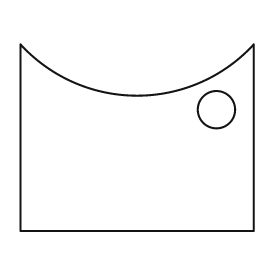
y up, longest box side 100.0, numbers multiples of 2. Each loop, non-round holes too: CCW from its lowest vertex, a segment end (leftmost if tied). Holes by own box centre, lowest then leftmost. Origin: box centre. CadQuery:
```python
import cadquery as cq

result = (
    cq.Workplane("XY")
    .moveTo(-50.0, -40.0)
    .lineTo(50.0, -40.0)
    .lineTo(50.0, 40.0)
    .threePointArc((0.0, 18.0), (-50.0, 40.0))
    .close()
    .moveTo(34.0, 12.0)
    .circle(8.0)
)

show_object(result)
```